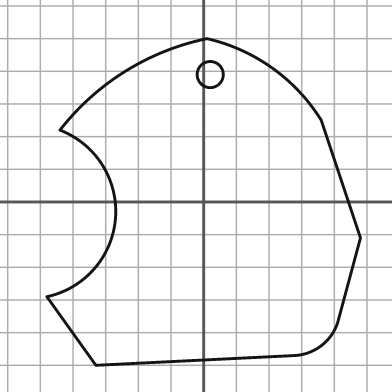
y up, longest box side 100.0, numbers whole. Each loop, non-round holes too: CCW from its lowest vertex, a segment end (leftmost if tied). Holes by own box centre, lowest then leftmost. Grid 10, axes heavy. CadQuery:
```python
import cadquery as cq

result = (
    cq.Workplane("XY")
    .moveTo(-33.0, -50.0)
    .lineTo(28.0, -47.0)
    .threePointArc((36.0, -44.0), (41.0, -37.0))
    .lineTo(48.0, -11.0)
    .lineTo(36.0, 25.0)
    .threePointArc((21.0, 41.0), (1.0, 50.0))
    .threePointArc((-24.0, 40.0), (-44.0, 22.0))
    .threePointArc((-27.0, -5.0), (-48.0, -29.0))
    .close()
    .moveTo(2.0, 39.0)
    .circle(4.0)
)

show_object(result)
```